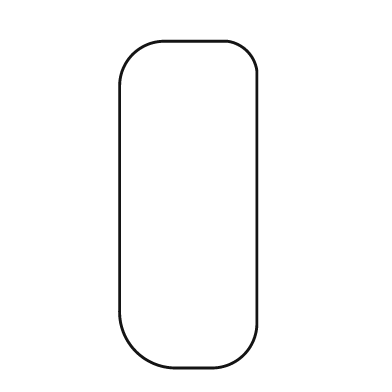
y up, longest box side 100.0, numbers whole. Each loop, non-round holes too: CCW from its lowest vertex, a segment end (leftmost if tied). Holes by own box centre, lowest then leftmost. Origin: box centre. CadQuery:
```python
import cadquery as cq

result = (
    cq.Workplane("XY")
    .moveTo(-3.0, -50.0)
    .lineTo(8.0, -50.0)
    .threePointArc((17.0, -46.0), (21.0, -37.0))
    .lineTo(21.0, 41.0)
    .threePointArc((18.0, 47.0), (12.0, 50.0))
    .lineTo(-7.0, 50.0)
    .threePointArc((-17.0, 46.0), (-21.0, 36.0))
    .lineTo(-21.0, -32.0)
    .threePointArc((-16.0, -45.0), (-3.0, -50.0))
    .close()
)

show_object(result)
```